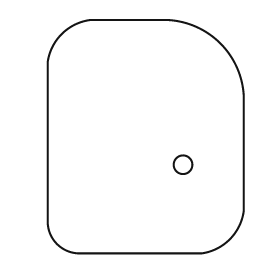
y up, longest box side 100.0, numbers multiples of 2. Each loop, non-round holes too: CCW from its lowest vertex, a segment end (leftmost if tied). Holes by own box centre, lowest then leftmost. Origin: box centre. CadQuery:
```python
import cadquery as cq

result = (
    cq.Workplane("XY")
    .moveTo(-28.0, -50.0)
    .lineTo(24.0, -50.0)
    .threePointArc((36.0, -44.0), (42.0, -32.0))
    .lineTo(42.0, 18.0)
    .threePointArc((32.0, 40.0), (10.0, 50.0))
    .lineTo(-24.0, 50.0)
    .threePointArc((-36.0, 44.0), (-42.0, 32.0))
    .lineTo(-42.0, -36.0)
    .threePointArc((-38.0, -46.0), (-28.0, -50.0))
    .close()
    .moveTo(16.0, -12.0)
    .circle(4.0)
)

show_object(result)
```